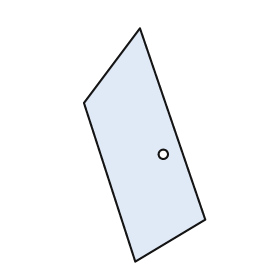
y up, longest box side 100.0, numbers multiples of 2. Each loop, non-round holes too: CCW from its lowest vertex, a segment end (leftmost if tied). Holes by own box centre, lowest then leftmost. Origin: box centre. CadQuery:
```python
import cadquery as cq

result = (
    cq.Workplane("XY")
    .moveTo(-4.0, -50.0)
    .lineTo(26.0, -32.0)
    .lineTo(-2.0, 50.0)
    .lineTo(-26.0, 18.0)
    .close()
    .moveTo(8.0, -4.0)
    .circle(2.0)
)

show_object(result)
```